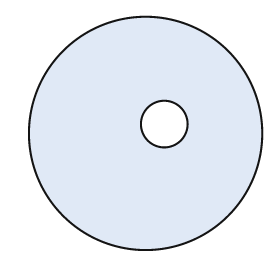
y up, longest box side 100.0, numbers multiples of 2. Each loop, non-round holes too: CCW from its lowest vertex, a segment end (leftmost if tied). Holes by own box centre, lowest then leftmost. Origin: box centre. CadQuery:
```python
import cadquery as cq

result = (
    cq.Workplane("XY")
    .moveTo(0.0, 0.0)
    .circle(50.0)
    .moveTo(8.0, 4.0)
    .circle(10.0)
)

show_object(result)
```